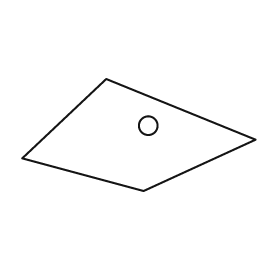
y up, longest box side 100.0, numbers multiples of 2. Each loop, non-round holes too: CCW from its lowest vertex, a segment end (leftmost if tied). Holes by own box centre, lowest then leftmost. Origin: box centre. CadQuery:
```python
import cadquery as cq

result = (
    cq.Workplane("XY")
    .moveTo(2.0, -24.0)
    .lineTo(50.0, -2.0)
    .lineTo(-14.0, 24.0)
    .lineTo(-50.0, -10.0)
    .close()
    .moveTo(4.0, 4.0)
    .circle(4.0)
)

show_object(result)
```